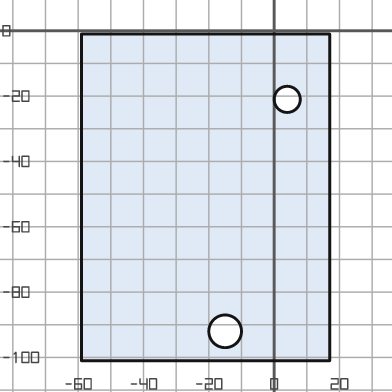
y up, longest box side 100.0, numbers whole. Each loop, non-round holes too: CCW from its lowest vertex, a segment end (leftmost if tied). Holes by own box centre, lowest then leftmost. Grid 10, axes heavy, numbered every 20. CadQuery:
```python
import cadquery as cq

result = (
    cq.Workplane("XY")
    .moveTo(-59.0, -101.0)
    .lineTo(17.0, -101.0)
    .lineTo(17.0, -1.0)
    .lineTo(-59.0, -1.0)
    .close()
    .moveTo(-15.0, -92.0)
    .circle(5.0)
    .moveTo(4.0, -21.0)
    .circle(4.0)
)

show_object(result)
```